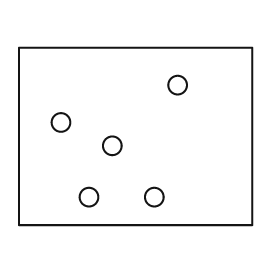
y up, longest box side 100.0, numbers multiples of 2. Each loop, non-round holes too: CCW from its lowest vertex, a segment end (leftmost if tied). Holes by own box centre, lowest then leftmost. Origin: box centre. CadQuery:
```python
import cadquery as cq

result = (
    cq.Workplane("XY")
    .moveTo(-50.0, -38.0)
    .lineTo(50.0, -38.0)
    .lineTo(50.0, 38.0)
    .lineTo(-50.0, 38.0)
    .close()
    .moveTo(-20.0, -26.0)
    .circle(4.0)
    .moveTo(8.0, -26.0)
    .circle(4.0)
    .moveTo(-10.0, -4.0)
    .circle(4.0)
    .moveTo(-32.0, 6.0)
    .circle(4.0)
    .moveTo(18.0, 22.0)
    .circle(4.0)
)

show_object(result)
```